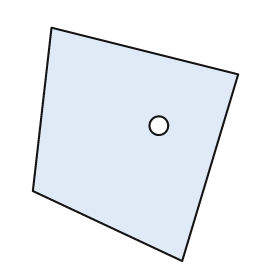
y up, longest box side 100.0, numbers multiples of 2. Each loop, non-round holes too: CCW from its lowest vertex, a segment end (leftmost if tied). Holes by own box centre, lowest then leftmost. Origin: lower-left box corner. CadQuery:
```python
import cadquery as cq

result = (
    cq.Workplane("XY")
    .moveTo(64.0, 0.0)
    .lineTo(88.0, 80.0)
    .lineTo(8.0, 100.0)
    .lineTo(0.0, 30.0)
    .close()
    .moveTo(54.0, 58.0)
    .circle(4.0)
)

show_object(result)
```